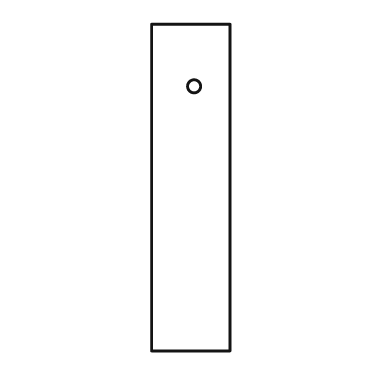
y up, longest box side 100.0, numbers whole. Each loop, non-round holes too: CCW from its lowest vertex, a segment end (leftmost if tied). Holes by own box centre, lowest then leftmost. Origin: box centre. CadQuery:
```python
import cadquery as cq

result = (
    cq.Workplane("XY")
    .moveTo(-12.0, -50.0)
    .lineTo(12.0, -50.0)
    .lineTo(12.0, 50.0)
    .lineTo(-12.0, 50.0)
    .close()
    .moveTo(1.0, 31.0)
    .circle(2.0)
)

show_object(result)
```